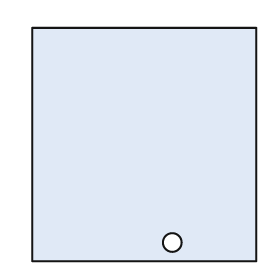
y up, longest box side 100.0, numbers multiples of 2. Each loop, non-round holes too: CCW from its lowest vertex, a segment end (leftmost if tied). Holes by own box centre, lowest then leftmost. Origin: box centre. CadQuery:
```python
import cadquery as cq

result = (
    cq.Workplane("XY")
    .moveTo(-48.0, -50.0)
    .lineTo(48.0, -50.0)
    .lineTo(48.0, 50.0)
    .lineTo(-48.0, 50.0)
    .close()
    .moveTo(12.0, -42.0)
    .circle(4.0)
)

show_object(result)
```